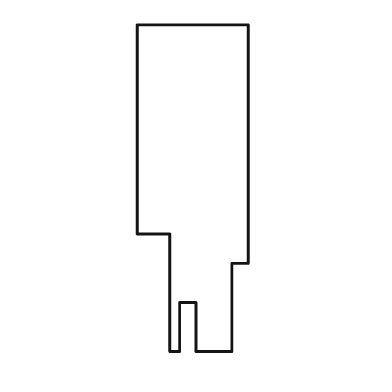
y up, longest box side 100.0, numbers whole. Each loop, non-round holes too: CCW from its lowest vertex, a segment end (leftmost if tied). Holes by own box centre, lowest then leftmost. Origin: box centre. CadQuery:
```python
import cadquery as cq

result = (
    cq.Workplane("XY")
    .moveTo(-7.0, -50.0)
    .lineTo(-4.0, -50.0)
    .lineTo(-4.0, -35.0)
    .lineTo(1.0, -35.0)
    .lineTo(1.0, -50.0)
    .lineTo(12.0, -50.0)
    .lineTo(12.0, -23.0)
    .lineTo(17.0, -23.0)
    .lineTo(17.0, 50.0)
    .lineTo(-17.0, 50.0)
    .lineTo(-17.0, -14.0)
    .lineTo(-7.0, -14.0)
    .close()
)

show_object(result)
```